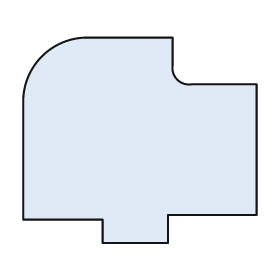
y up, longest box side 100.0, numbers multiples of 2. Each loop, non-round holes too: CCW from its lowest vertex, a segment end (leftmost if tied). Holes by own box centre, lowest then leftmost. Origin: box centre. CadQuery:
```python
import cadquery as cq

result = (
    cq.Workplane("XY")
    .moveTo(-16.0, -44.0)
    .lineTo(12.0, -44.0)
    .lineTo(12.0, -32.0)
    .lineTo(50.0, -32.0)
    .lineTo(50.0, 24.0)
    .lineTo(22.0, 24.0)
    .threePointArc((16.0, 26.0), (14.0, 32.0))
    .lineTo(14.0, 44.0)
    .lineTo(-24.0, 44.0)
    .threePointArc((-42.0, 36.0), (-50.0, 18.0))
    .lineTo(-50.0, -34.0)
    .lineTo(-16.0, -34.0)
    .close()
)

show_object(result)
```